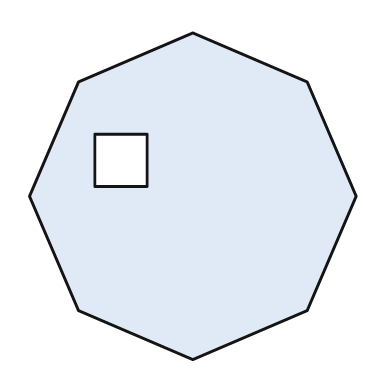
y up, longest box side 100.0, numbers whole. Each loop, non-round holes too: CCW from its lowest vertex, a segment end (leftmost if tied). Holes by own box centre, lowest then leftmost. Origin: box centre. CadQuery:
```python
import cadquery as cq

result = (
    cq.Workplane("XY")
    .moveTo(0.0, -50.0)
    .lineTo(35.0, -35.0)
    .lineTo(50.0, 0.0)
    .lineTo(35.0, 35.0)
    .lineTo(0.0, 50.0)
    .lineTo(-35.0, 35.0)
    .lineTo(-50.0, 0.0)
    .lineTo(-35.0, -35.0)
    .close()
    .moveTo(-30.0, 3.0)
    .lineTo(-14.0, 3.0)
    .lineTo(-14.0, 19.0)
    .lineTo(-30.0, 19.0)
    .close()
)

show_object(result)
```